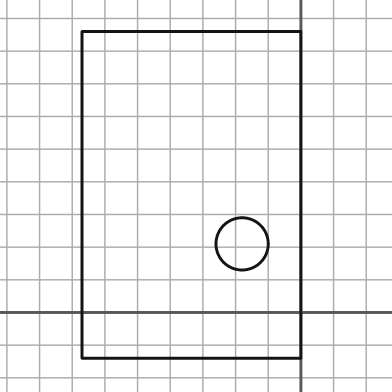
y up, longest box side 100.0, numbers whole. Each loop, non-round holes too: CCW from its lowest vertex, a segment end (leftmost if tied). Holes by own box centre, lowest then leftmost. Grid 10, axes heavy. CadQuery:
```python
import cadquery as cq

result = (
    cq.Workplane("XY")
    .moveTo(-67.0, -14.0)
    .lineTo(0.0, -14.0)
    .lineTo(0.0, 86.0)
    .lineTo(-67.0, 86.0)
    .close()
    .moveTo(-18.0, 21.0)
    .circle(8.0)
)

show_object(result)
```